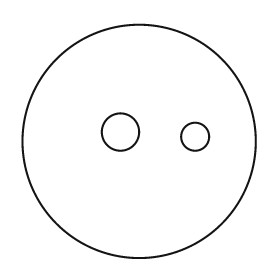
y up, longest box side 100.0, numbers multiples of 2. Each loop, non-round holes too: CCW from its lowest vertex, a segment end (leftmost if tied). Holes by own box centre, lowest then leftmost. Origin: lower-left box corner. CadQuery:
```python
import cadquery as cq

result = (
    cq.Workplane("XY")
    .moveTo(50.0, 50.0)
    .circle(50.0)
    .moveTo(74.0, 52.0)
    .circle(6.0)
    .moveTo(42.0, 54.0)
    .circle(8.0)
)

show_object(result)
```